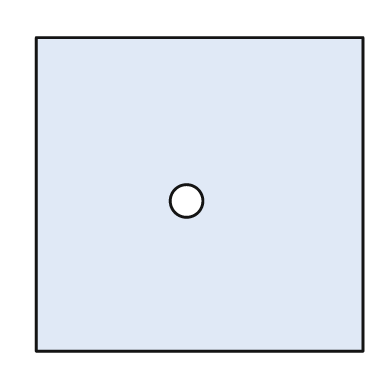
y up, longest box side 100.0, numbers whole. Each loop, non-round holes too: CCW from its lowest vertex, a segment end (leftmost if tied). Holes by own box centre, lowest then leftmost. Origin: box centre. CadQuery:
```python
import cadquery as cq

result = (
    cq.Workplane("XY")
    .moveTo(-50.0, -48.0)
    .lineTo(50.0, -48.0)
    .lineTo(50.0, 48.0)
    .lineTo(-50.0, 48.0)
    .close()
    .moveTo(-4.0, -2.0)
    .circle(5.0)
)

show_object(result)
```